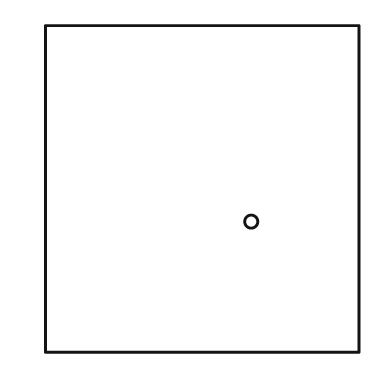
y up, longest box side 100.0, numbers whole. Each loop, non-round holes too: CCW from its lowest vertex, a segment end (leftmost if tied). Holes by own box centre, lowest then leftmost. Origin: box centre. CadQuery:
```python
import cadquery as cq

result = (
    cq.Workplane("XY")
    .moveTo(-48.0, -50.0)
    .lineTo(48.0, -50.0)
    .lineTo(48.0, 50.0)
    .lineTo(-48.0, 50.0)
    .close()
    .moveTo(15.0, -10.0)
    .circle(2.0)
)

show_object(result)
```